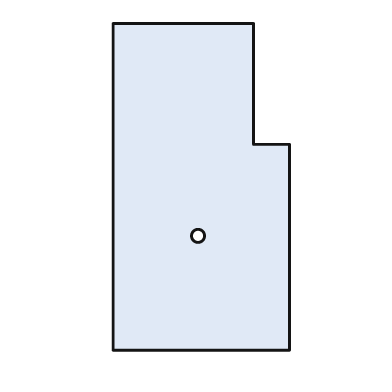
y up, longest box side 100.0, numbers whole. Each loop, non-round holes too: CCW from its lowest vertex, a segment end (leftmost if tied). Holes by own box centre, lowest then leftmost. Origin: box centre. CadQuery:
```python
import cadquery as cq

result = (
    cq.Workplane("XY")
    .moveTo(-27.0, -50.0)
    .lineTo(27.0, -50.0)
    .lineTo(27.0, 13.0)
    .lineTo(16.0, 13.0)
    .lineTo(16.0, 50.0)
    .lineTo(-27.0, 50.0)
    .close()
    .moveTo(-1.0, -15.0)
    .circle(2.0)
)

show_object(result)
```